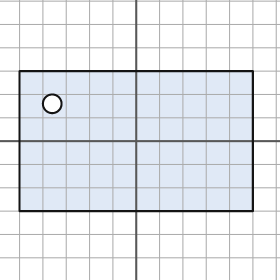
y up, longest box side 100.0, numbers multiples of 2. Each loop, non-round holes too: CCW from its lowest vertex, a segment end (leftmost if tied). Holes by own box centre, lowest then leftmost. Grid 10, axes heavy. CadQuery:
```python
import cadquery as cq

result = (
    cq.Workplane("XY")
    .moveTo(-50.0, -30.0)
    .lineTo(50.0, -30.0)
    .lineTo(50.0, 30.0)
    .lineTo(-50.0, 30.0)
    .close()
    .moveTo(-36.0, 16.0)
    .circle(4.0)
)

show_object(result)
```